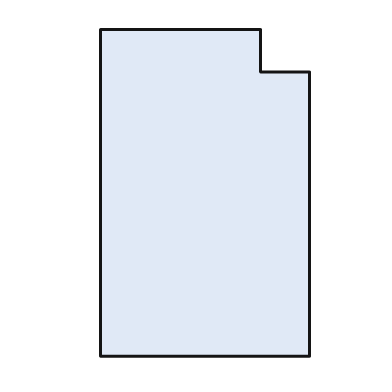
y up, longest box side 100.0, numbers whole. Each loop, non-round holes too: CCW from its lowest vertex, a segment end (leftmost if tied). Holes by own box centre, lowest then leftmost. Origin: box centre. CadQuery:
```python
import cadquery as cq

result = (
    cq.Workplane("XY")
    .moveTo(-32.0, -50.0)
    .lineTo(32.0, -50.0)
    .lineTo(32.0, 37.0)
    .lineTo(17.0, 37.0)
    .lineTo(17.0, 50.0)
    .lineTo(-32.0, 50.0)
    .close()
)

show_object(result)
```